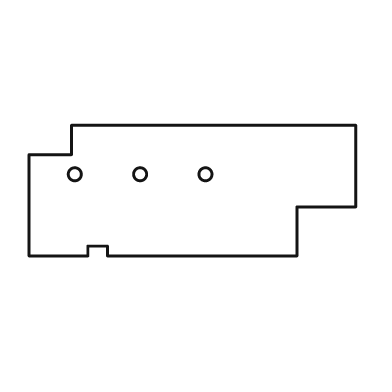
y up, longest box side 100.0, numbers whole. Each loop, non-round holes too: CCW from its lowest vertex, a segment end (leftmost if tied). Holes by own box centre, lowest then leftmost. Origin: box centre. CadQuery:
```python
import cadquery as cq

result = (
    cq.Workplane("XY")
    .moveTo(-50.0, -20.0)
    .lineTo(-32.0, -20.0)
    .lineTo(-32.0, -17.0)
    .lineTo(-26.0, -17.0)
    .lineTo(-26.0, -20.0)
    .lineTo(32.0, -20.0)
    .lineTo(32.0, -5.0)
    .lineTo(50.0, -5.0)
    .lineTo(50.0, 20.0)
    .lineTo(-37.0, 20.0)
    .lineTo(-37.0, 11.0)
    .lineTo(-50.0, 11.0)
    .close()
    .moveTo(-36.0, 5.0)
    .circle(2.0)
    .moveTo(-16.0, 5.0)
    .circle(2.0)
    .moveTo(4.0, 5.0)
    .circle(2.0)
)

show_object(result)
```